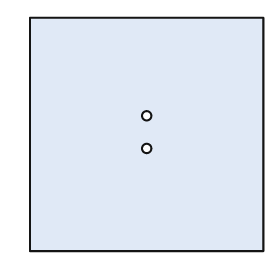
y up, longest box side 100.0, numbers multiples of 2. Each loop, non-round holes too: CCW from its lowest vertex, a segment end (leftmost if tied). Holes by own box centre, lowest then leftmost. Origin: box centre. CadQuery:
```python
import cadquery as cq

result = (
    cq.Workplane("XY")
    .moveTo(-50.0, -50.0)
    .lineTo(50.0, -50.0)
    .lineTo(50.0, 50.0)
    .lineTo(-50.0, 50.0)
    .close()
    .moveTo(0.0, -6.0)
    .circle(2.0)
    .moveTo(0.0, 8.0)
    .circle(2.0)
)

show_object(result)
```